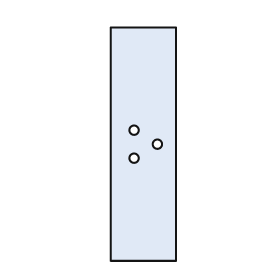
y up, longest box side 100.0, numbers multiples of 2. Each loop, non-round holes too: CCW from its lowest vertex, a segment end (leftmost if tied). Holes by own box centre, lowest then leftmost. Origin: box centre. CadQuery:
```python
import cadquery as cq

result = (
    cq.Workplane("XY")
    .moveTo(-14.0, -50.0)
    .lineTo(14.0, -50.0)
    .lineTo(14.0, 50.0)
    .lineTo(-14.0, 50.0)
    .close()
    .moveTo(-4.0, -6.0)
    .circle(2.0)
    .moveTo(6.0, 0.0)
    .circle(2.0)
    .moveTo(-4.0, 6.0)
    .circle(2.0)
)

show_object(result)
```